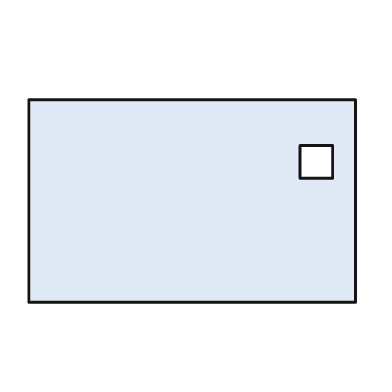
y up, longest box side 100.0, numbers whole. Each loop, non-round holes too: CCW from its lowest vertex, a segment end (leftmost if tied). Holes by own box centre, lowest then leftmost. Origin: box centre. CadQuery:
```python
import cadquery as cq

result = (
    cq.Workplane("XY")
    .moveTo(-50.0, -31.0)
    .lineTo(50.0, -31.0)
    .lineTo(50.0, 31.0)
    .lineTo(-50.0, 31.0)
    .close()
    .moveTo(33.0, 7.0)
    .lineTo(43.0, 7.0)
    .lineTo(43.0, 17.0)
    .lineTo(33.0, 17.0)
    .close()
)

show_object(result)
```